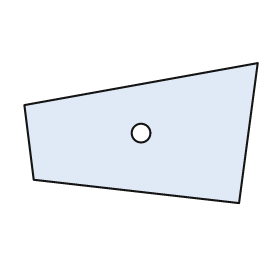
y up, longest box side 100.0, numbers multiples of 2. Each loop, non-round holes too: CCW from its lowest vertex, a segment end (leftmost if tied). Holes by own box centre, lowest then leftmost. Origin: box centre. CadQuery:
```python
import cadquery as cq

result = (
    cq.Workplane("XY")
    .moveTo(42.0, -30.0)
    .lineTo(50.0, 30.0)
    .lineTo(-50.0, 12.0)
    .lineTo(-46.0, -20.0)
    .close()
    .moveTo(0.0, 0.0)
    .circle(4.0)
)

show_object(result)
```